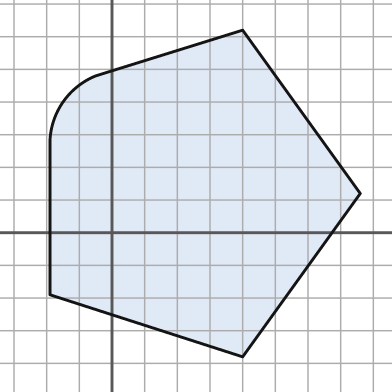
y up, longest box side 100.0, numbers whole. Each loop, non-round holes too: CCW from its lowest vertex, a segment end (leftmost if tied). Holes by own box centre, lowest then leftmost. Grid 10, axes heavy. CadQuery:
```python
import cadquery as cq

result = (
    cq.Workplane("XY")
    .moveTo(40.0, -38.0)
    .lineTo(76.0, 12.0)
    .lineTo(40.0, 62.0)
    .lineTo(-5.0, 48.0)
    .threePointArc((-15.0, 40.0), (-19.0, 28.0))
    .lineTo(-19.0, -19.0)
    .close()
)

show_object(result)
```